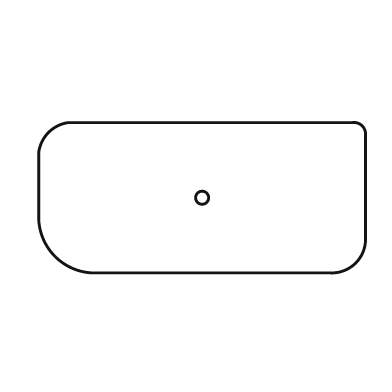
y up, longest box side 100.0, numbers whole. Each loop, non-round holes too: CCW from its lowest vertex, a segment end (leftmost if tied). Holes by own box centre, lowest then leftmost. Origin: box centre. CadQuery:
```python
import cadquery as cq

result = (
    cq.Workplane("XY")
    .moveTo(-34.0, -23.0)
    .lineTo(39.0, -23.0)
    .threePointArc((47.0, -20.0), (50.0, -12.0))
    .lineTo(50.0, 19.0)
    .threePointArc((49.0, 22.0), (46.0, 23.0))
    .lineTo(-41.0, 23.0)
    .threePointArc((-47.0, 20.0), (-50.0, 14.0))
    .lineTo(-50.0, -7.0)
    .threePointArc((-45.0, -18.0), (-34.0, -23.0))
    .close()
    .moveTo(0.0, 0.0)
    .circle(2.0)
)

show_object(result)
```